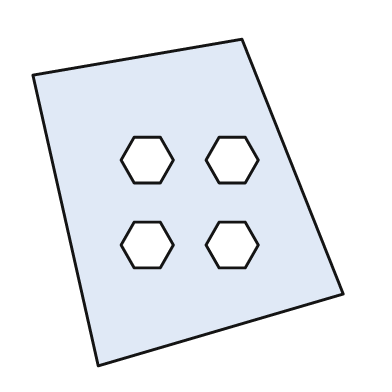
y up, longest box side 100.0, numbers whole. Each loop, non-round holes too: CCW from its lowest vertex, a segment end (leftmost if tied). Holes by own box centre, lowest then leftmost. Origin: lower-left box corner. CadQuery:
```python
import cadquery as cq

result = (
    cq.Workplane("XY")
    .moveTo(20.0, 0.0)
    .lineTo(95.0, 22.0)
    .lineTo(64.0, 100.0)
    .lineTo(0.0, 89.0)
    .close()
    .moveTo(31.0, 30.0)
    .lineTo(39.0, 30.0)
    .lineTo(43.0, 37.0)
    .lineTo(39.0, 44.0)
    .lineTo(31.0, 44.0)
    .lineTo(27.0, 37.0)
    .close()
    .moveTo(57.0, 30.0)
    .lineTo(65.0, 30.0)
    .lineTo(69.0, 37.0)
    .lineTo(65.0, 44.0)
    .lineTo(57.0, 44.0)
    .lineTo(53.0, 37.0)
    .close()
    .moveTo(31.0, 56.0)
    .lineTo(39.0, 56.0)
    .lineTo(43.0, 63.0)
    .lineTo(39.0, 70.0)
    .lineTo(31.0, 70.0)
    .lineTo(27.0, 63.0)
    .close()
    .moveTo(57.0, 56.0)
    .lineTo(65.0, 56.0)
    .lineTo(69.0, 63.0)
    .lineTo(65.0, 70.0)
    .lineTo(57.0, 70.0)
    .lineTo(53.0, 63.0)
    .close()
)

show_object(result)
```